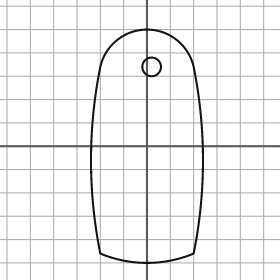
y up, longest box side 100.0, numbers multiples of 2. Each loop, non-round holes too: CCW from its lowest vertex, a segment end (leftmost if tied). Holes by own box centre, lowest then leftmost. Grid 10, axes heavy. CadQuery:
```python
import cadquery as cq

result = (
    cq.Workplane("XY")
    .moveTo(-20.0, -46.0)
    .threePointArc((0.0, -50.0), (20.0, -46.0))
    .threePointArc((24.0, -6.0), (20.0, 34.0))
    .threePointArc((0.0, 50.0), (-20.0, 34.0))
    .threePointArc((-24.0, -6.0), (-20.0, -46.0))
    .close()
    .moveTo(2.0, 34.0)
    .circle(4.0)
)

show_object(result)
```